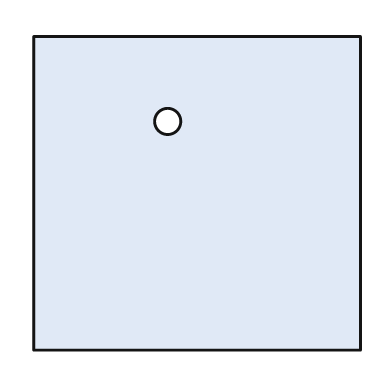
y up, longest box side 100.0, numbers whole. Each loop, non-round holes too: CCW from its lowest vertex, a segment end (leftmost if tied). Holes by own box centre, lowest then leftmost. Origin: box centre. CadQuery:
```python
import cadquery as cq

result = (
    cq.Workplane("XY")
    .moveTo(-50.0, -48.0)
    .lineTo(50.0, -48.0)
    .lineTo(50.0, 48.0)
    .lineTo(-50.0, 48.0)
    .close()
    .moveTo(-9.0, 22.0)
    .circle(4.0)
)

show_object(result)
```